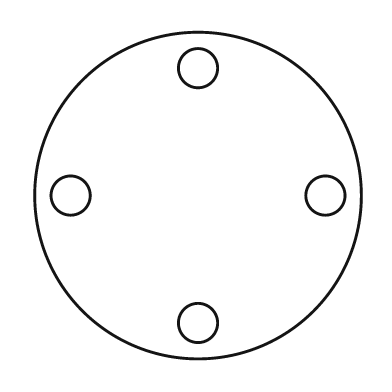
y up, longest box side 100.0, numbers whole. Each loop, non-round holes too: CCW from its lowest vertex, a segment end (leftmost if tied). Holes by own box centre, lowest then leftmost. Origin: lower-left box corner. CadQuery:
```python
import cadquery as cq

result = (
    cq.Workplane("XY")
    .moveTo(50.0, 50.0)
    .circle(50.0)
    .moveTo(50.0, 11.0)
    .circle(6.0)
    .moveTo(11.0, 50.0)
    .circle(6.0)
    .moveTo(89.0, 50.0)
    .circle(6.0)
    .moveTo(50.0, 89.0)
    .circle(6.0)
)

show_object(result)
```